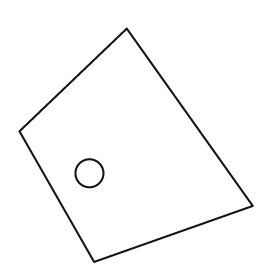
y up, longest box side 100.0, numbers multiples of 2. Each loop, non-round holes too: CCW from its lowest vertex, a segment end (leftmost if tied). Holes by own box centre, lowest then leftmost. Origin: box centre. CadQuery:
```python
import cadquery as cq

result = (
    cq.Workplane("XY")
    .moveTo(-18.0, -50.0)
    .lineTo(50.0, -26.0)
    .lineTo(-4.0, 50.0)
    .lineTo(-50.0, 6.0)
    .close()
    .moveTo(-20.0, -12.0)
    .circle(6.0)
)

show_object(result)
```